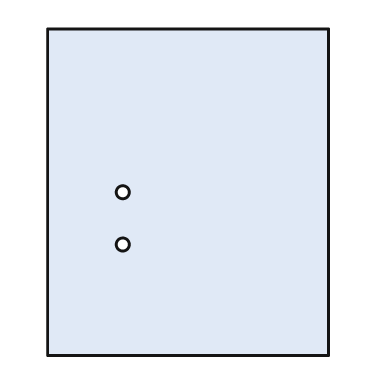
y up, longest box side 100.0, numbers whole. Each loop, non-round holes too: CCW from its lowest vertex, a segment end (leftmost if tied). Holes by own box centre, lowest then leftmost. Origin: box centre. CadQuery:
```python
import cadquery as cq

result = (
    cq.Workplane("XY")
    .moveTo(-43.0, -50.0)
    .lineTo(43.0, -50.0)
    .lineTo(43.0, 50.0)
    .lineTo(-43.0, 50.0)
    .close()
    .moveTo(-20.0, -16.0)
    .circle(2.0)
    .moveTo(-20.0, 0.0)
    .circle(2.0)
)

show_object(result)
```